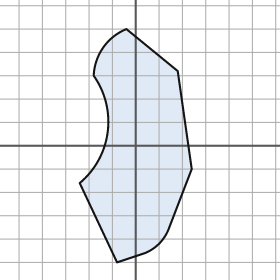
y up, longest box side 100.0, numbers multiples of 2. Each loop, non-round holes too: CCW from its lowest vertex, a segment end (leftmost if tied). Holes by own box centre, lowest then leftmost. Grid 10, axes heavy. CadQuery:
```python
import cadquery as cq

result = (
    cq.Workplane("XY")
    .moveTo(-8.0, -50.0)
    .lineTo(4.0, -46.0)
    .threePointArc((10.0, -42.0), (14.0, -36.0))
    .lineTo(24.0, -10.0)
    .lineTo(18.0, 32.0)
    .lineTo(-4.0, 50.0)
    .threePointArc((-14.0, 42.0), (-18.0, 30.0))
    .threePointArc((-12.0, 6.0), (-24.0, -16.0))
    .close()
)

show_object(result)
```